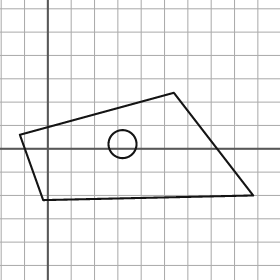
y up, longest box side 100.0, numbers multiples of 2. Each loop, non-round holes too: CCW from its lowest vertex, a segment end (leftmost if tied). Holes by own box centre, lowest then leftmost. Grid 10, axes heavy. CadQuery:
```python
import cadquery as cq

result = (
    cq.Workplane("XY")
    .moveTo(-2.0, -22.0)
    .lineTo(88.0, -20.0)
    .lineTo(54.0, 24.0)
    .lineTo(-12.0, 6.0)
    .close()
    .moveTo(32.0, 2.0)
    .circle(6.0)
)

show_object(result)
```